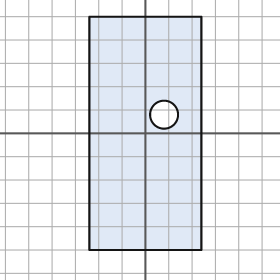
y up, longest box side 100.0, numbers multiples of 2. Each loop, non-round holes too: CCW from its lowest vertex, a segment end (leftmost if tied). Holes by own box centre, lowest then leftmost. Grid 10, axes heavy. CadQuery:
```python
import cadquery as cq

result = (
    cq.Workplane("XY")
    .moveTo(-24.0, -50.0)
    .lineTo(24.0, -50.0)
    .lineTo(24.0, 50.0)
    .lineTo(-24.0, 50.0)
    .close()
    .moveTo(8.0, 8.0)
    .circle(6.0)
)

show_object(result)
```